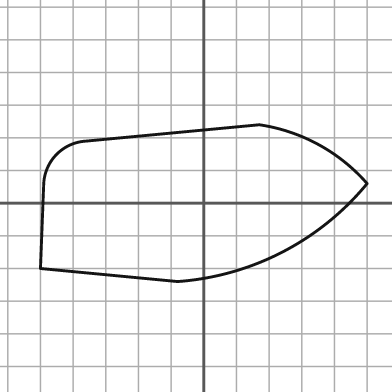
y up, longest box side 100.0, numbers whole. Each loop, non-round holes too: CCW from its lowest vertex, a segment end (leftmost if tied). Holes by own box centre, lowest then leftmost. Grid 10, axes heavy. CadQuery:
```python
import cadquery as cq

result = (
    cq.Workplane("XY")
    .moveTo(-8.0, -24.0)
    .threePointArc((24.0, -15.0), (50.0, 6.0))
    .threePointArc((35.0, 18.0), (17.0, 24.0))
    .lineTo(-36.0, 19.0)
    .threePointArc((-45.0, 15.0), (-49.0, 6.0))
    .lineTo(-50.0, -20.0)
    .close()
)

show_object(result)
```